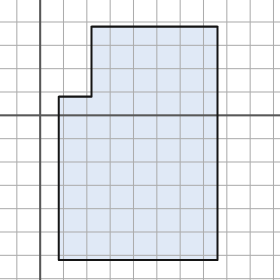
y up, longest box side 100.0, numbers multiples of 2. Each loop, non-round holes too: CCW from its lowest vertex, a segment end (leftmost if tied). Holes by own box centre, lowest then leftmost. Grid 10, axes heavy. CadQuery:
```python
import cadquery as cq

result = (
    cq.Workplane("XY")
    .moveTo(8.0, -62.0)
    .lineTo(76.0, -62.0)
    .lineTo(76.0, 38.0)
    .lineTo(22.0, 38.0)
    .lineTo(22.0, 8.0)
    .lineTo(8.0, 8.0)
    .close()
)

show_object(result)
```